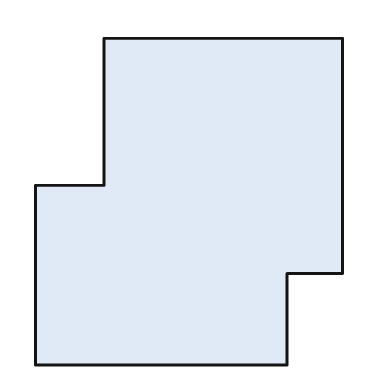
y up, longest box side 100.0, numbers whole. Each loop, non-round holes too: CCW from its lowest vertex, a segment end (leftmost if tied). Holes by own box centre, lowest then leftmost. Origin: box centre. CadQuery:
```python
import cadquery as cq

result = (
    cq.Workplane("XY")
    .moveTo(-47.0, -50.0)
    .lineTo(30.0, -50.0)
    .lineTo(30.0, -22.0)
    .lineTo(47.0, -22.0)
    .lineTo(47.0, 50.0)
    .lineTo(-26.0, 50.0)
    .lineTo(-26.0, 5.0)
    .lineTo(-47.0, 5.0)
    .close()
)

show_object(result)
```